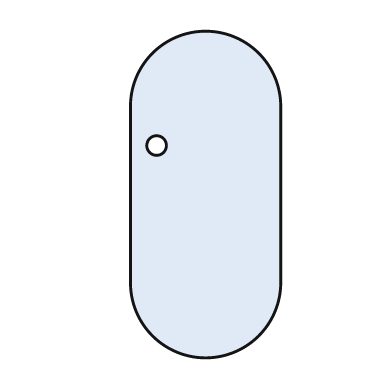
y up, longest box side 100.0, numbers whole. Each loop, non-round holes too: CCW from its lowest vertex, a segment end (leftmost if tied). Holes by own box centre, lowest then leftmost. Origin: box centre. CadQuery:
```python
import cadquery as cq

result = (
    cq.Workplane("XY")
    .moveTo(-23.0, -27.0)
    .threePointArc((0.0, -50.0), (23.0, -27.0))
    .lineTo(23.0, 27.0)
    .threePointArc((0.0, 50.0), (-23.0, 27.0))
    .close()
    .moveTo(-15.0, 15.0)
    .circle(3.0)
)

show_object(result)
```